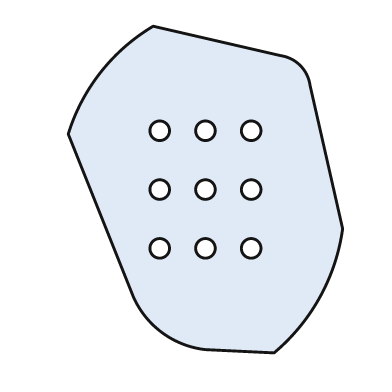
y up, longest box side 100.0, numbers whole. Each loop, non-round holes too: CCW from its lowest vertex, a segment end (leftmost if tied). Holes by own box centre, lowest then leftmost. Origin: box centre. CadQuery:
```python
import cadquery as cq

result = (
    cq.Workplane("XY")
    .moveTo(21.0, -50.0)
    .threePointArc((35.0, -33.0), (42.0, -12.0))
    .lineTo(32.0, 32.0)
    .threePointArc((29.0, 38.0), (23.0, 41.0))
    .lineTo(-16.0, 50.0)
    .threePointArc((-32.0, 36.0), (-42.0, 17.0))
    .lineTo(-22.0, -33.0)
    .threePointArc((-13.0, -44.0), (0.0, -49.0))
    .close()
    .moveTo(-14.0, -18.0)
    .circle(3.0)
    .moveTo(0.0, -18.0)
    .circle(3.0)
    .moveTo(14.0, -18.0)
    .circle(3.0)
    .moveTo(-14.0, 0.0)
    .circle(3.0)
    .moveTo(0.0, 0.0)
    .circle(3.0)
    .moveTo(14.0, 0.0)
    .circle(3.0)
    .moveTo(-14.0, 18.0)
    .circle(3.0)
    .moveTo(0.0, 18.0)
    .circle(3.0)
    .moveTo(14.0, 18.0)
    .circle(3.0)
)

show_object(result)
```